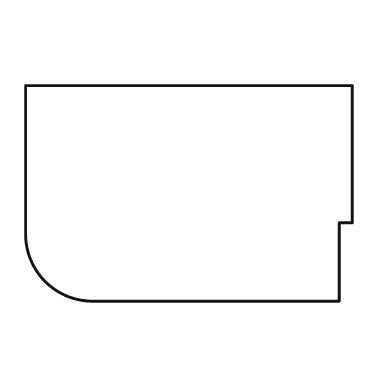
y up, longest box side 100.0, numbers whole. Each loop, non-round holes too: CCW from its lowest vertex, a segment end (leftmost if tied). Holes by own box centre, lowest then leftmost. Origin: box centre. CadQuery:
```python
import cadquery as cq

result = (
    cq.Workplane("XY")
    .moveTo(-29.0, -33.0)
    .lineTo(46.0, -33.0)
    .lineTo(46.0, -9.0)
    .lineTo(50.0, -9.0)
    .lineTo(50.0, 33.0)
    .lineTo(-50.0, 33.0)
    .lineTo(-50.0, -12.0)
    .threePointArc((-44.0, -27.0), (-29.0, -33.0))
    .close()
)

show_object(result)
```